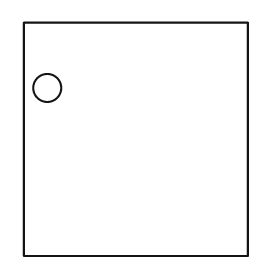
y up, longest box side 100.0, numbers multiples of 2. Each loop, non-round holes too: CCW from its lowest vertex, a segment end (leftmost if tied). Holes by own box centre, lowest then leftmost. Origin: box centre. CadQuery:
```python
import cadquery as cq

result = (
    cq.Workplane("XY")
    .moveTo(-48.0, -50.0)
    .lineTo(48.0, -50.0)
    .lineTo(48.0, 50.0)
    .lineTo(-48.0, 50.0)
    .close()
    .moveTo(-38.0, 22.0)
    .circle(6.0)
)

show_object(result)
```